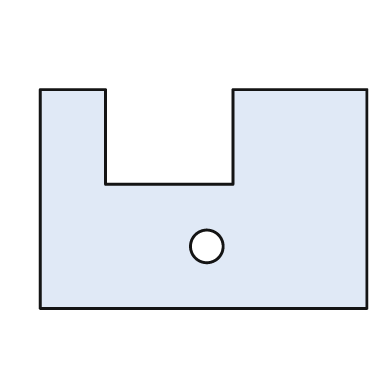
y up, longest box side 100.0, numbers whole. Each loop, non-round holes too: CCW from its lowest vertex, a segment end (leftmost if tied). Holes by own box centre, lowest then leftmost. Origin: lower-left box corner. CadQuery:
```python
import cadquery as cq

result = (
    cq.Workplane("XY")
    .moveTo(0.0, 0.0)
    .lineTo(100.0, 0.0)
    .lineTo(100.0, 67.0)
    .lineTo(59.0, 67.0)
    .lineTo(59.0, 38.0)
    .lineTo(20.0, 38.0)
    .lineTo(20.0, 67.0)
    .lineTo(0.0, 67.0)
    .close()
    .moveTo(51.0, 19.0)
    .circle(5.0)
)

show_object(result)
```